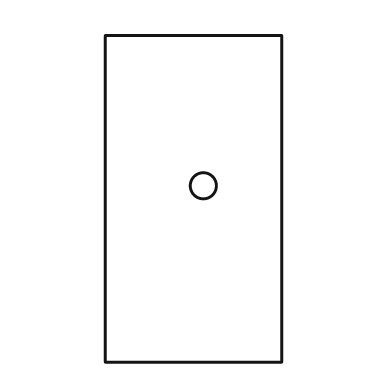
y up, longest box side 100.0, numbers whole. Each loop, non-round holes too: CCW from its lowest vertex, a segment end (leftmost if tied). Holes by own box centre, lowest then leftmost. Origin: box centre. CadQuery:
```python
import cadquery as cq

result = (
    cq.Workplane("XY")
    .moveTo(-27.0, -50.0)
    .lineTo(27.0, -50.0)
    .lineTo(27.0, 50.0)
    .lineTo(-27.0, 50.0)
    .close()
    .moveTo(3.0, 4.0)
    .circle(4.0)
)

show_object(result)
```